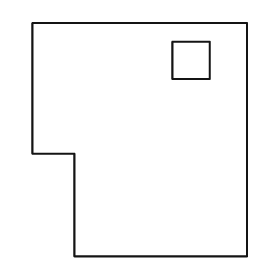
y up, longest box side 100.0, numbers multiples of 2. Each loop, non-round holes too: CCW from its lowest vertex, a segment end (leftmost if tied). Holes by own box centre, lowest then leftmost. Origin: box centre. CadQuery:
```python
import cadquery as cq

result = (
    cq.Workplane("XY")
    .moveTo(-28.0, -50.0)
    .lineTo(46.0, -50.0)
    .lineTo(46.0, 50.0)
    .lineTo(-46.0, 50.0)
    .lineTo(-46.0, -6.0)
    .lineTo(-28.0, -6.0)
    .close()
    .moveTo(14.0, 26.0)
    .lineTo(30.0, 26.0)
    .lineTo(30.0, 42.0)
    .lineTo(14.0, 42.0)
    .close()
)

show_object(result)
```